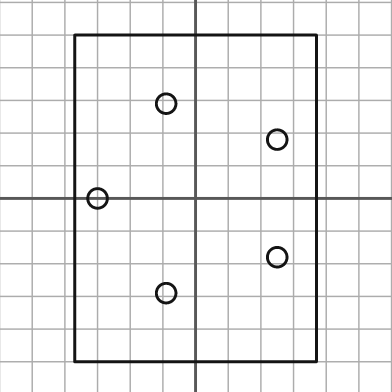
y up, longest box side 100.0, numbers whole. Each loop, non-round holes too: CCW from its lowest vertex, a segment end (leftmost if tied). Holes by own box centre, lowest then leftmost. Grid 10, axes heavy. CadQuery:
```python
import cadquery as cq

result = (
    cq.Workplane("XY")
    .moveTo(-37.0, -50.0)
    .lineTo(37.0, -50.0)
    .lineTo(37.0, 50.0)
    .lineTo(-37.0, 50.0)
    .close()
    .moveTo(-9.0, -29.0)
    .circle(3.0)
    .moveTo(25.0, -18.0)
    .circle(3.0)
    .moveTo(-30.0, 0.0)
    .circle(3.0)
    .moveTo(25.0, 18.0)
    .circle(3.0)
    .moveTo(-9.0, 29.0)
    .circle(3.0)
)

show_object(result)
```